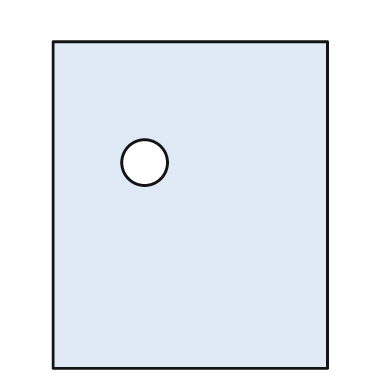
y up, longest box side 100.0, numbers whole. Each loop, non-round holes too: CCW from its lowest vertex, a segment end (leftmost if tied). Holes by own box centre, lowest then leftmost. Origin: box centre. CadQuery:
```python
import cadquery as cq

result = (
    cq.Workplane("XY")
    .moveTo(-42.0, -50.0)
    .lineTo(42.0, -50.0)
    .lineTo(42.0, 50.0)
    .lineTo(-42.0, 50.0)
    .close()
    .moveTo(-14.0, 13.0)
    .circle(7.0)
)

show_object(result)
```